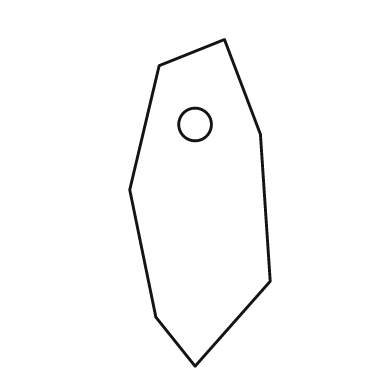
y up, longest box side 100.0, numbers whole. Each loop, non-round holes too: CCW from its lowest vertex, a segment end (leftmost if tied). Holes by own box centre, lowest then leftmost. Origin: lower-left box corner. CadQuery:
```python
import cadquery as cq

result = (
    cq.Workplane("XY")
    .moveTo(20.0, 0.0)
    .lineTo(43.0, 26.0)
    .lineTo(40.0, 71.0)
    .lineTo(29.0, 100.0)
    .lineTo(9.0, 92.0)
    .lineTo(0.0, 54.0)
    .lineTo(8.0, 15.0)
    .close()
    .moveTo(20.0, 74.0)
    .circle(5.0)
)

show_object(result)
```